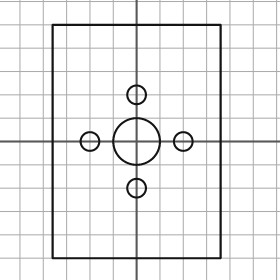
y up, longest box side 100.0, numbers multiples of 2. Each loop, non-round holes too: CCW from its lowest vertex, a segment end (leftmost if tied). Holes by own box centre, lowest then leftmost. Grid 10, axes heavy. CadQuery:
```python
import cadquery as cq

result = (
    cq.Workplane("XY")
    .moveTo(-36.0, -50.0)
    .lineTo(36.0, -50.0)
    .lineTo(36.0, 50.0)
    .lineTo(-36.0, 50.0)
    .close()
    .moveTo(0.0, -20.0)
    .circle(4.0)
    .moveTo(-20.0, 0.0)
    .circle(4.0)
    .moveTo(0.0, 0.0)
    .circle(10.0)
    .moveTo(20.0, 0.0)
    .circle(4.0)
    .moveTo(0.0, 20.0)
    .circle(4.0)
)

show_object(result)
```